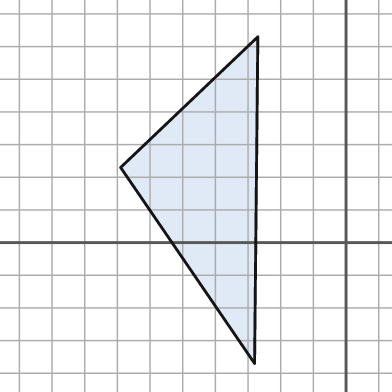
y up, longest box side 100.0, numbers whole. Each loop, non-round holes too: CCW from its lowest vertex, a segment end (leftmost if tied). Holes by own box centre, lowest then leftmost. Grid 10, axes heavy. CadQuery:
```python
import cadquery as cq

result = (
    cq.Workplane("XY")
    .moveTo(-28.0, -37.0)
    .lineTo(-27.0, 63.0)
    .lineTo(-69.0, 23.0)
    .close()
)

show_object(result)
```